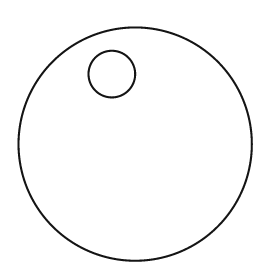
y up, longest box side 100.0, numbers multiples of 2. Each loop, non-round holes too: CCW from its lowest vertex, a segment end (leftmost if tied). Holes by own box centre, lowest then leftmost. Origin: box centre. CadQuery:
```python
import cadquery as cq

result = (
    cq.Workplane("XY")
    .moveTo(0.0, 0.0)
    .circle(50.0)
    .moveTo(-10.0, 30.0)
    .circle(10.0)
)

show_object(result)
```